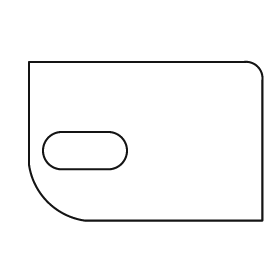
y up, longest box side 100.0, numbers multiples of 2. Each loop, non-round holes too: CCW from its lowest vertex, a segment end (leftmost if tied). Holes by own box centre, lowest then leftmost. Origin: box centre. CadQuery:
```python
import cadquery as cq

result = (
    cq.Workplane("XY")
    .moveTo(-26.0, -34.0)
    .lineTo(50.0, -34.0)
    .lineTo(50.0, 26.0)
    .threePointArc((48.0, 32.0), (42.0, 34.0))
    .lineTo(-50.0, 34.0)
    .lineTo(-50.0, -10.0)
    .threePointArc((-42.0, -26.0), (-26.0, -34.0))
    .close()
    .moveTo(-36.0, -12.0)
    .lineTo(-16.0, -12.0)
    .threePointArc((-8.0, -4.0), (-16.0, 4.0))
    .lineTo(-36.0, 4.0)
    .threePointArc((-44.0, -4.0), (-36.0, -12.0))
    .close()
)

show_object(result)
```